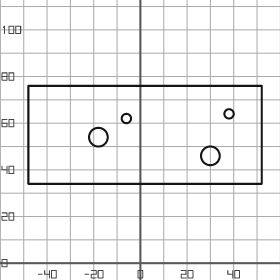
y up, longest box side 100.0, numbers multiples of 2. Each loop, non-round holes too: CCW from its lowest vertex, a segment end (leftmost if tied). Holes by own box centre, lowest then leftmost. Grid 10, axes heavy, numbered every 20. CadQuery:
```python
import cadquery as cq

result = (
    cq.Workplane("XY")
    .moveTo(-48.0, 34.0)
    .lineTo(52.0, 34.0)
    .lineTo(52.0, 76.0)
    .lineTo(-48.0, 76.0)
    .close()
    .moveTo(30.0, 46.0)
    .circle(4.0)
    .moveTo(-18.0, 54.0)
    .circle(4.0)
    .moveTo(-6.0, 62.0)
    .circle(2.0)
    .moveTo(38.0, 64.0)
    .circle(2.0)
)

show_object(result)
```